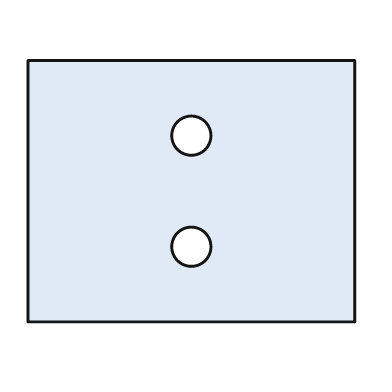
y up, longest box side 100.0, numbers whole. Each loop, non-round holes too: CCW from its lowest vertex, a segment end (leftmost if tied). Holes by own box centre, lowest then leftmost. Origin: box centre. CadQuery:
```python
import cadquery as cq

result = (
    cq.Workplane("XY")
    .moveTo(-50.0, -40.0)
    .lineTo(50.0, -40.0)
    .lineTo(50.0, 40.0)
    .lineTo(-50.0, 40.0)
    .close()
    .moveTo(0.0, -17.0)
    .circle(6.0)
    .moveTo(0.0, 17.0)
    .circle(6.0)
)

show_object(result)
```